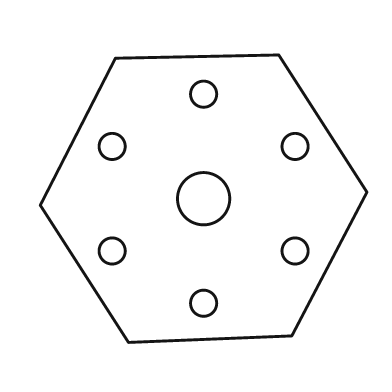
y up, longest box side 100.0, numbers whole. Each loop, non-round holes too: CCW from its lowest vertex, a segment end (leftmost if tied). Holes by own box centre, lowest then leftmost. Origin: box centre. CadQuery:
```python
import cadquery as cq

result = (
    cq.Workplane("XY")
    .moveTo(-23.0, -44.0)
    .lineTo(27.0, -42.0)
    .lineTo(50.0, 2.0)
    .lineTo(23.0, 44.0)
    .lineTo(-27.0, 43.0)
    .lineTo(-50.0, -2.0)
    .close()
    .moveTo(0.0, -32.0)
    .circle(4.0)
    .moveTo(-28.0, -16.0)
    .circle(4.0)
    .moveTo(28.0, -16.0)
    .circle(4.0)
    .moveTo(0.0, 0.0)
    .circle(8.0)
    .moveTo(-28.0, 16.0)
    .circle(4.0)
    .moveTo(28.0, 16.0)
    .circle(4.0)
    .moveTo(0.0, 32.0)
    .circle(4.0)
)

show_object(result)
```